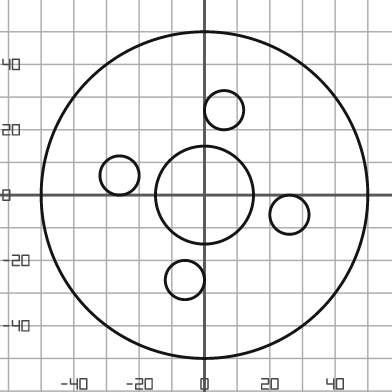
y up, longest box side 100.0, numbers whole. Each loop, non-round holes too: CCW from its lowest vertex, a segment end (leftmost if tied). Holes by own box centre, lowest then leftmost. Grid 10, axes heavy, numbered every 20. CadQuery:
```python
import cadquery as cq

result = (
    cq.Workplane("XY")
    .moveTo(0.0, 0.0)
    .circle(50.0)
    .moveTo(-6.0, -26.0)
    .circle(6.0)
    .moveTo(26.0, -6.0)
    .circle(6.0)
    .moveTo(0.0, 0.0)
    .circle(15.0)
    .moveTo(-26.0, 6.0)
    .circle(6.0)
    .moveTo(6.0, 26.0)
    .circle(6.0)
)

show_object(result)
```